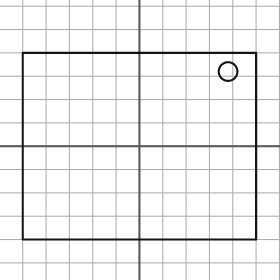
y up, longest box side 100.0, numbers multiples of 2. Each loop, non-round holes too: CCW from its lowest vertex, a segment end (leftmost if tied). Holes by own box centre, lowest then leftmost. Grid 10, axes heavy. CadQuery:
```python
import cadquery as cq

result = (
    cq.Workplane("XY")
    .moveTo(-50.0, -40.0)
    .lineTo(50.0, -40.0)
    .lineTo(50.0, 40.0)
    .lineTo(-50.0, 40.0)
    .close()
    .moveTo(38.0, 32.0)
    .circle(4.0)
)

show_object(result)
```